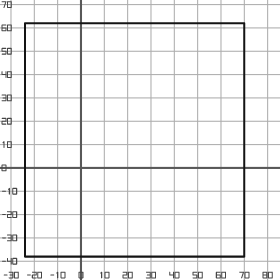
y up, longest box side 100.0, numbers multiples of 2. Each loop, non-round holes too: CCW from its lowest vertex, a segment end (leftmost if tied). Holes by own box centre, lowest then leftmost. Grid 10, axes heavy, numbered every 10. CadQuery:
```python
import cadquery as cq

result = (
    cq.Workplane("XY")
    .moveTo(-24.0, -38.0)
    .lineTo(70.0, -38.0)
    .lineTo(70.0, 62.0)
    .lineTo(-24.0, 62.0)
    .close()
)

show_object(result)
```